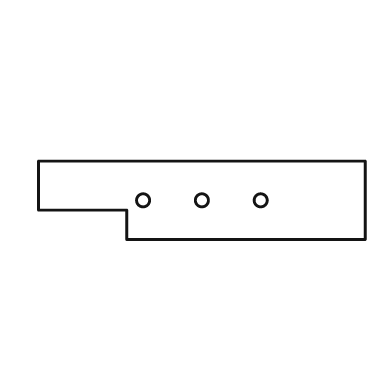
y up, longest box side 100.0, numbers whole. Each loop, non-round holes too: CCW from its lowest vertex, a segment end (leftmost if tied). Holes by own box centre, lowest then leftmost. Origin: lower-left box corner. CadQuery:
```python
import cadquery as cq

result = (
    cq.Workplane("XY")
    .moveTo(27.0, 0.0)
    .lineTo(100.0, 0.0)
    .lineTo(100.0, 24.0)
    .lineTo(0.0, 24.0)
    .lineTo(0.0, 9.0)
    .lineTo(27.0, 9.0)
    .close()
    .moveTo(32.0, 12.0)
    .circle(2.0)
    .moveTo(50.0, 12.0)
    .circle(2.0)
    .moveTo(68.0, 12.0)
    .circle(2.0)
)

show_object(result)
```